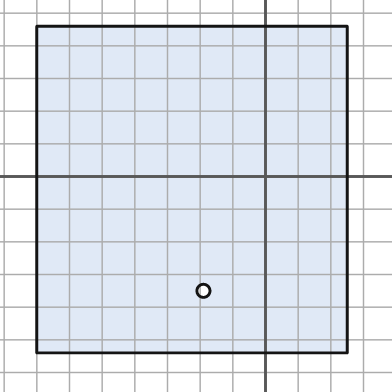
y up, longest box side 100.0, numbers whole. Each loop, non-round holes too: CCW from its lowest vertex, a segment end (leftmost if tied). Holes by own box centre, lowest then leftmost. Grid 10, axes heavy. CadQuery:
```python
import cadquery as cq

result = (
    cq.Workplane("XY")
    .moveTo(-70.0, -54.0)
    .lineTo(25.0, -54.0)
    .lineTo(25.0, 46.0)
    .lineTo(-70.0, 46.0)
    .close()
    .moveTo(-19.0, -35.0)
    .circle(2.0)
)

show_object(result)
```